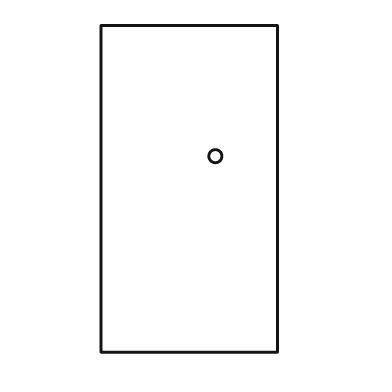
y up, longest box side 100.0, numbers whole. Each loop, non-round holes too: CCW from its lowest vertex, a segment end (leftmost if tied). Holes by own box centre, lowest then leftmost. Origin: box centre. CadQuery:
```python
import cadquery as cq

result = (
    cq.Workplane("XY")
    .moveTo(-27.0, -50.0)
    .lineTo(27.0, -50.0)
    .lineTo(27.0, 50.0)
    .lineTo(-27.0, 50.0)
    .close()
    .moveTo(8.0, 10.0)
    .circle(2.0)
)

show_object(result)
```